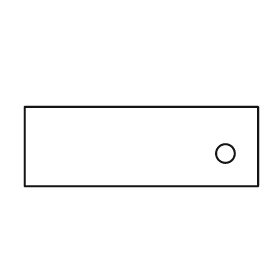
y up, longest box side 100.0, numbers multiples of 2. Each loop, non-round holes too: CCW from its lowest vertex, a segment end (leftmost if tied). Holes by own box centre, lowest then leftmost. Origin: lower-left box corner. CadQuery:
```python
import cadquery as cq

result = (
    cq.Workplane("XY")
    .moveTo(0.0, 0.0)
    .lineTo(100.0, 0.0)
    .lineTo(100.0, 34.0)
    .lineTo(0.0, 34.0)
    .close()
    .moveTo(86.0, 14.0)
    .circle(4.0)
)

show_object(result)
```